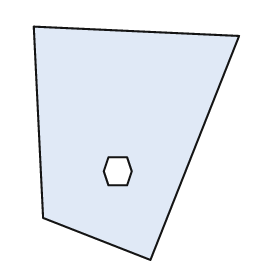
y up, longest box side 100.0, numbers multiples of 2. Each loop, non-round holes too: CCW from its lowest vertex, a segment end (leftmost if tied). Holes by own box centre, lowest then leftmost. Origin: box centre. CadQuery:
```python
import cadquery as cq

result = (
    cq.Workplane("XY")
    .moveTo(6.0, -50.0)
    .lineTo(44.0, 46.0)
    .lineTo(-44.0, 50.0)
    .lineTo(-40.0, -32.0)
    .close()
    .moveTo(-12.0, -18.0)
    .lineTo(-4.0, -18.0)
    .lineTo(-2.0, -12.0)
    .lineTo(-4.0, -6.0)
    .lineTo(-12.0, -6.0)
    .lineTo(-14.0, -12.0)
    .close()
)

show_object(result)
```